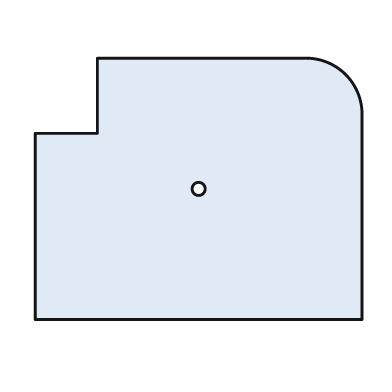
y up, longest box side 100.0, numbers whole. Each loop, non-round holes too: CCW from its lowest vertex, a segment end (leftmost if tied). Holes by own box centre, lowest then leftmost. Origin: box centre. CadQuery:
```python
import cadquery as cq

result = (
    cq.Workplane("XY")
    .moveTo(-50.0, -40.0)
    .lineTo(50.0, -40.0)
    .lineTo(50.0, 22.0)
    .threePointArc((45.0, 35.0), (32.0, 40.0))
    .lineTo(-31.0, 40.0)
    .lineTo(-31.0, 17.0)
    .lineTo(-50.0, 17.0)
    .close()
    .moveTo(0.0, 0.0)
    .circle(2.0)
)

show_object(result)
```